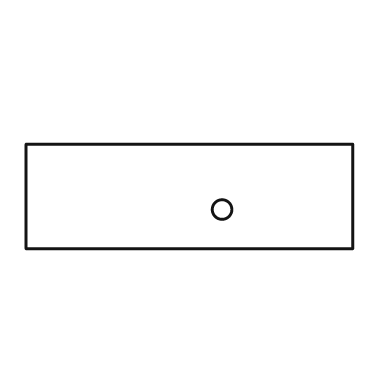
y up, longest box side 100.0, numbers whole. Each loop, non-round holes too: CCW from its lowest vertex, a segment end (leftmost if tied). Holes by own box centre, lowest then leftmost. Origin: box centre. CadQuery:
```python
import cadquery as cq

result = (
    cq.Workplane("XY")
    .moveTo(-50.0, -16.0)
    .lineTo(50.0, -16.0)
    .lineTo(50.0, 16.0)
    .lineTo(-50.0, 16.0)
    .close()
    .moveTo(10.0, -4.0)
    .circle(3.0)
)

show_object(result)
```